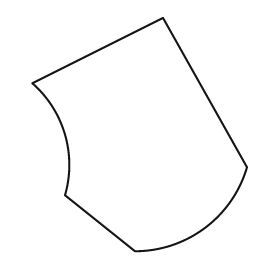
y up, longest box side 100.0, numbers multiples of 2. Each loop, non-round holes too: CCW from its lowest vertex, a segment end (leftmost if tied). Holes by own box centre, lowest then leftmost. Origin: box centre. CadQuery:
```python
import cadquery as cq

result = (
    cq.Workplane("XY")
    .moveTo(-2.0, -50.0)
    .threePointArc((28.0, -40.0), (46.0, -14.0))
    .lineTo(10.0, 50.0)
    .lineTo(-46.0, 22.0)
    .threePointArc((-32.0, 0.0), (-32.0, -26.0))
    .close()
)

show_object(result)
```